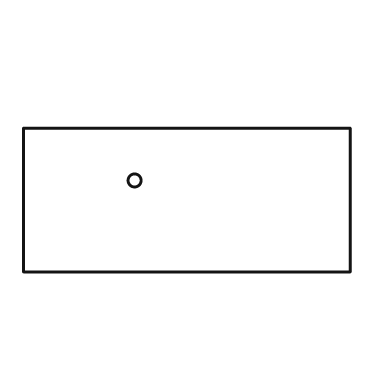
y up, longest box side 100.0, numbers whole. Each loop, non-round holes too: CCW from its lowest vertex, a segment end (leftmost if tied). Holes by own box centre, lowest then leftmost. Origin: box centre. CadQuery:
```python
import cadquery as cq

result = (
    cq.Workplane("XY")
    .moveTo(-50.0, -22.0)
    .lineTo(50.0, -22.0)
    .lineTo(50.0, 22.0)
    .lineTo(-50.0, 22.0)
    .close()
    .moveTo(-16.0, 6.0)
    .circle(2.0)
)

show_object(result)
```